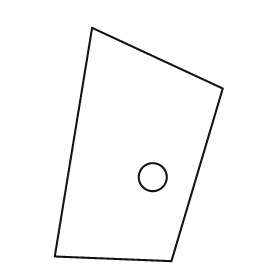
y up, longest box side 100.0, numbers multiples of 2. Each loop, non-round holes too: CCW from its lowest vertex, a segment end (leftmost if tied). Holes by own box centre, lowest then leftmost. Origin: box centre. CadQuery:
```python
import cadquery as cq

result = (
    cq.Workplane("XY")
    .moveTo(14.0, -50.0)
    .lineTo(36.0, 24.0)
    .lineTo(-20.0, 50.0)
    .lineTo(-36.0, -48.0)
    .close()
    .moveTo(6.0, -14.0)
    .circle(6.0)
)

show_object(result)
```